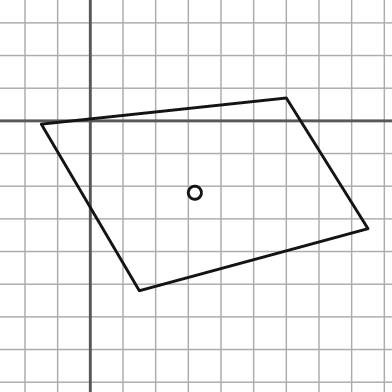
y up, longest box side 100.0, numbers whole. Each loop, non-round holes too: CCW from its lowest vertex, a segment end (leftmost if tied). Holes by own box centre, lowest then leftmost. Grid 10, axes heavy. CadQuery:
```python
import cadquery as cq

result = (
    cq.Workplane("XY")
    .moveTo(15.0, -52.0)
    .lineTo(85.0, -33.0)
    .lineTo(60.0, 7.0)
    .lineTo(-15.0, -1.0)
    .close()
    .moveTo(32.0, -22.0)
    .circle(2.0)
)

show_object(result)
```